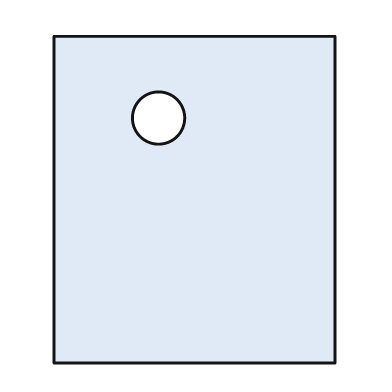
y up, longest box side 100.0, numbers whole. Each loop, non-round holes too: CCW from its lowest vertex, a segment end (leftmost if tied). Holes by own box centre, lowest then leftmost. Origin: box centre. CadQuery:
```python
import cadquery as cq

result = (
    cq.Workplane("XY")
    .moveTo(-43.0, -50.0)
    .lineTo(43.0, -50.0)
    .lineTo(43.0, 50.0)
    .lineTo(-43.0, 50.0)
    .close()
    .moveTo(-11.0, 25.0)
    .circle(8.0)
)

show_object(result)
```